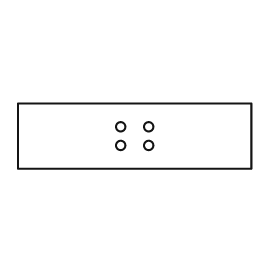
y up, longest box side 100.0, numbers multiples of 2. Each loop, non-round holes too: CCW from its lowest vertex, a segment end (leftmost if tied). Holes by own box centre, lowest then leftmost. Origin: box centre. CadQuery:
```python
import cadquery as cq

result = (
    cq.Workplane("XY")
    .moveTo(-50.0, -14.0)
    .lineTo(50.0, -14.0)
    .lineTo(50.0, 14.0)
    .lineTo(-50.0, 14.0)
    .close()
    .moveTo(-6.0, -4.0)
    .circle(2.0)
    .moveTo(6.0, -4.0)
    .circle(2.0)
    .moveTo(-6.0, 4.0)
    .circle(2.0)
    .moveTo(6.0, 4.0)
    .circle(2.0)
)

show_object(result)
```